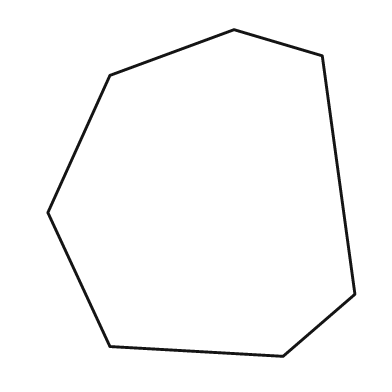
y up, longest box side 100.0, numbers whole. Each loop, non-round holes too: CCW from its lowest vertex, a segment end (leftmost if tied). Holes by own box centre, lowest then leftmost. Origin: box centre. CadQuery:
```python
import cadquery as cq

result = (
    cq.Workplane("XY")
    .moveTo(25.0, -50.0)
    .lineTo(47.0, -31.0)
    .lineTo(37.0, 42.0)
    .lineTo(10.0, 50.0)
    .lineTo(-28.0, 36.0)
    .lineTo(-47.0, -6.0)
    .lineTo(-28.0, -47.0)
    .close()
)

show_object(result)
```